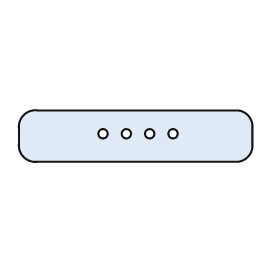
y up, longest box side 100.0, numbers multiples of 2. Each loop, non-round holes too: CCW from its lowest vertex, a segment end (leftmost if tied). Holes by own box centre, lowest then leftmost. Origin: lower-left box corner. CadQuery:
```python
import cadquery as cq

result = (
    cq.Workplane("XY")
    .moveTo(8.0, 0.0)
    .lineTo(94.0, 0.0)
    .threePointArc((98.0, 2.0), (100.0, 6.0))
    .lineTo(100.0, 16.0)
    .threePointArc((98.0, 20.0), (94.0, 22.0))
    .lineTo(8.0, 22.0)
    .threePointArc((2.0, 20.0), (0.0, 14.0))
    .lineTo(0.0, 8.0)
    .threePointArc((2.0, 2.0), (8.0, 0.0))
    .close()
    .moveTo(36.0, 12.0)
    .circle(2.0)
    .moveTo(46.0, 12.0)
    .circle(2.0)
    .moveTo(56.0, 12.0)
    .circle(2.0)
    .moveTo(66.0, 12.0)
    .circle(2.0)
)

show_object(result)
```